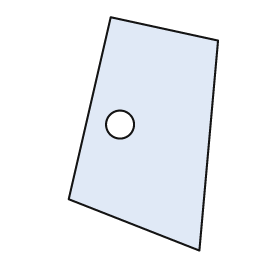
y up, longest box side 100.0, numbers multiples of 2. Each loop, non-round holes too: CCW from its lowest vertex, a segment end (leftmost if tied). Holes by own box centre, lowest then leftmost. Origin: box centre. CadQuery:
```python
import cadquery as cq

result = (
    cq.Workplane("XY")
    .moveTo(24.0, -50.0)
    .lineTo(32.0, 40.0)
    .lineTo(-14.0, 50.0)
    .lineTo(-32.0, -28.0)
    .close()
    .moveTo(-10.0, 4.0)
    .circle(6.0)
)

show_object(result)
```